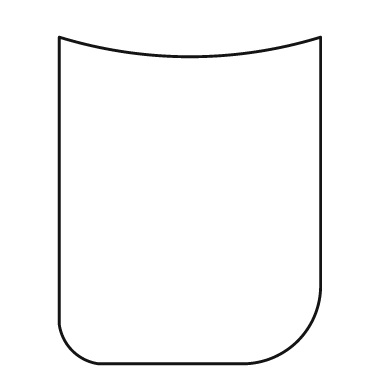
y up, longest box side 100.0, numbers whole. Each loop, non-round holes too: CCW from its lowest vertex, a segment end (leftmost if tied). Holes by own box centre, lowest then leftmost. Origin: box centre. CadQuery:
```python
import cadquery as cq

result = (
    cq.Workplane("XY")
    .moveTo(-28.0, -50.0)
    .lineTo(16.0, -50.0)
    .threePointArc((33.0, -43.0), (40.0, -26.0))
    .lineTo(40.0, 50.0)
    .threePointArc((0.0, 44.0), (-40.0, 50.0))
    .lineTo(-40.0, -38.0)
    .threePointArc((-36.0, -46.0), (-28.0, -50.0))
    .close()
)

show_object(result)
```